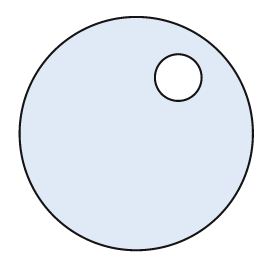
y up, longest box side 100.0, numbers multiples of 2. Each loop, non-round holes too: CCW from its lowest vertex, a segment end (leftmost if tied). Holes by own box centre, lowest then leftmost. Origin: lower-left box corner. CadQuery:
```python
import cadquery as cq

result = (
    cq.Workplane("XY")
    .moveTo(50.0, 50.0)
    .circle(50.0)
    .moveTo(68.0, 74.0)
    .circle(10.0)
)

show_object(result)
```